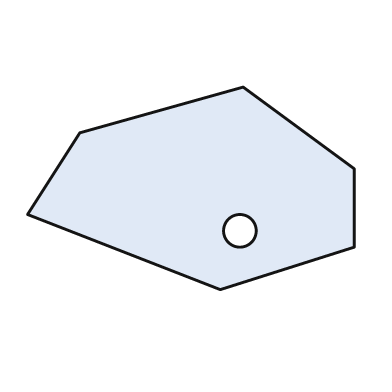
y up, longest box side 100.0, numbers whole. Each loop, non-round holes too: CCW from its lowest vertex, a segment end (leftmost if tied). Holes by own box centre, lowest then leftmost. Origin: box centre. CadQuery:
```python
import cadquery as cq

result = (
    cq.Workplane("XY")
    .moveTo(9.0, -31.0)
    .lineTo(50.0, -18.0)
    .lineTo(50.0, 6.0)
    .lineTo(16.0, 31.0)
    .lineTo(-34.0, 17.0)
    .lineTo(-50.0, -8.0)
    .close()
    .moveTo(15.0, -13.0)
    .circle(5.0)
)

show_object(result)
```